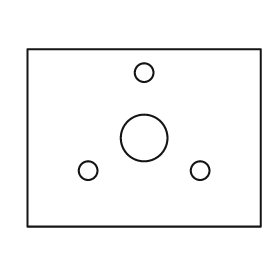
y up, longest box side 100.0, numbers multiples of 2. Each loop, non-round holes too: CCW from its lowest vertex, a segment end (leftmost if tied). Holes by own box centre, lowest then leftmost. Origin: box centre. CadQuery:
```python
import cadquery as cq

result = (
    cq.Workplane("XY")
    .moveTo(-50.0, -38.0)
    .lineTo(50.0, -38.0)
    .lineTo(50.0, 38.0)
    .lineTo(-50.0, 38.0)
    .close()
    .moveTo(-24.0, -14.0)
    .circle(4.0)
    .moveTo(24.0, -14.0)
    .circle(4.0)
    .moveTo(0.0, 0.0)
    .circle(10.0)
    .moveTo(0.0, 28.0)
    .circle(4.0)
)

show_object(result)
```